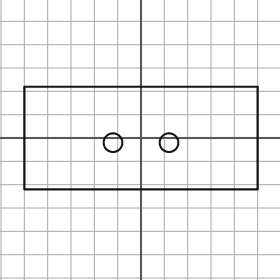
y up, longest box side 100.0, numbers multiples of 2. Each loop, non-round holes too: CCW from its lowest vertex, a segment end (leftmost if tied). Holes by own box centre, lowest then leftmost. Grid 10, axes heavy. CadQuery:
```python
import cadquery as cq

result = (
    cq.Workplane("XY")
    .moveTo(-50.0, -22.0)
    .lineTo(50.0, -22.0)
    .lineTo(50.0, 22.0)
    .lineTo(-50.0, 22.0)
    .close()
    .moveTo(-12.0, -2.0)
    .circle(4.0)
    .moveTo(12.0, -2.0)
    .circle(4.0)
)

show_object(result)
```